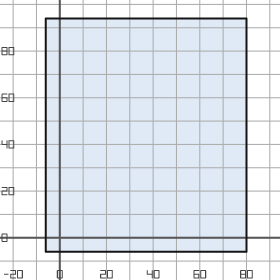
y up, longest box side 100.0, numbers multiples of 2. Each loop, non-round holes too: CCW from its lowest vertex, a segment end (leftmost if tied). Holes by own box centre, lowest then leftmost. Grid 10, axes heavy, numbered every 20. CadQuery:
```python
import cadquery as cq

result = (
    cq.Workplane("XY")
    .moveTo(-6.0, -6.0)
    .lineTo(80.0, -6.0)
    .lineTo(80.0, 94.0)
    .lineTo(-6.0, 94.0)
    .close()
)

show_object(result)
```